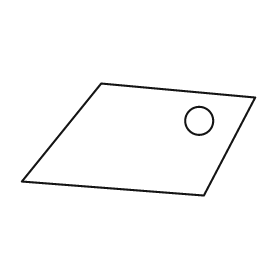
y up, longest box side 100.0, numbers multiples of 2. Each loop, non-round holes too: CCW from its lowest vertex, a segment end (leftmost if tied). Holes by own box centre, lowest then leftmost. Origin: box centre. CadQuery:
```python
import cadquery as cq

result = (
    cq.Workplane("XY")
    .moveTo(28.0, -24.0)
    .lineTo(50.0, 18.0)
    .lineTo(-16.0, 24.0)
    .lineTo(-50.0, -18.0)
    .close()
    .moveTo(26.0, 8.0)
    .circle(6.0)
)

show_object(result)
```